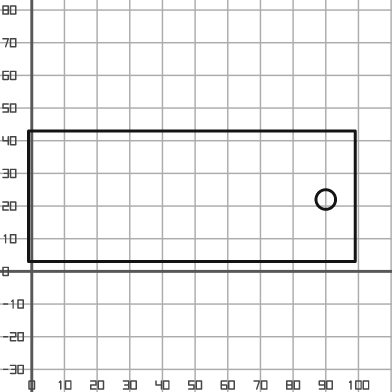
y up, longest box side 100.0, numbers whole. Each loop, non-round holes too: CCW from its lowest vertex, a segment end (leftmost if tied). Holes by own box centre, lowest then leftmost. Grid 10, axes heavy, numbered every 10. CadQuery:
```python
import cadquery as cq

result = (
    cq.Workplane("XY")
    .moveTo(-1.0, 3.0)
    .lineTo(99.0, 3.0)
    .lineTo(99.0, 43.0)
    .lineTo(-1.0, 43.0)
    .close()
    .moveTo(90.0, 22.0)
    .circle(3.0)
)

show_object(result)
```